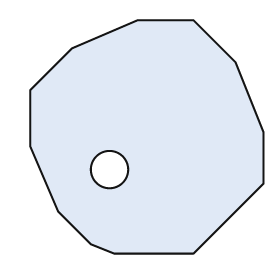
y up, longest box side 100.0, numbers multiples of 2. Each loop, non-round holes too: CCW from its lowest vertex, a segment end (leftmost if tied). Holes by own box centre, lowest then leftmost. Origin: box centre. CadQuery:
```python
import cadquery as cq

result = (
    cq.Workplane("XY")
    .moveTo(-14.0, -50.0)
    .lineTo(20.0, -50.0)
    .lineTo(50.0, -20.0)
    .lineTo(50.0, 2.0)
    .lineTo(38.0, 32.0)
    .lineTo(20.0, 50.0)
    .lineTo(-4.0, 50.0)
    .lineTo(-32.0, 38.0)
    .lineTo(-50.0, 20.0)
    .lineTo(-50.0, -4.0)
    .lineTo(-38.0, -32.0)
    .lineTo(-24.0, -46.0)
    .close()
    .moveTo(-16.0, -14.0)
    .circle(8.0)
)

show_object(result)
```